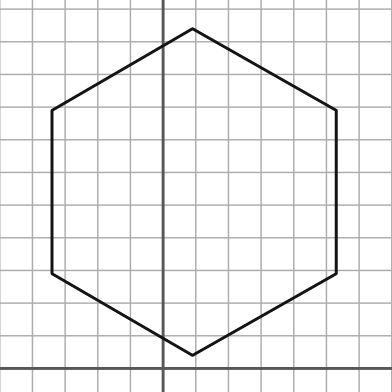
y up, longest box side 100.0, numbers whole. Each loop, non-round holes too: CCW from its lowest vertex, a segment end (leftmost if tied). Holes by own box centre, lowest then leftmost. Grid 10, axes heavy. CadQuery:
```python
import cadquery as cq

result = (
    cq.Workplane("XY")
    .moveTo(9.0, 4.0)
    .lineTo(53.0, 29.0)
    .lineTo(53.0, 79.0)
    .lineTo(9.0, 104.0)
    .lineTo(-34.0, 79.0)
    .lineTo(-34.0, 29.0)
    .close()
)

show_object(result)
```